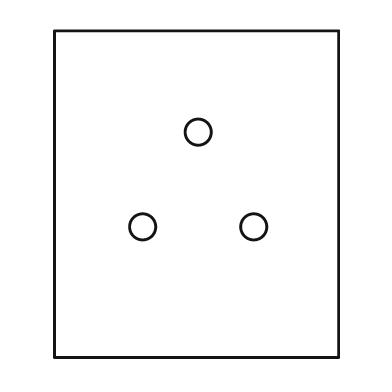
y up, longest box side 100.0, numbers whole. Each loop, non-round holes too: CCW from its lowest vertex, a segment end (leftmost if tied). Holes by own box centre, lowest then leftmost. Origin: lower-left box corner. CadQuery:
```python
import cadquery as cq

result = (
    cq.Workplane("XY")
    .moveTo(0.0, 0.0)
    .lineTo(87.0, 0.0)
    .lineTo(87.0, 100.0)
    .lineTo(0.0, 100.0)
    .close()
    .moveTo(27.0, 40.0)
    .circle(4.0)
    .moveTo(61.0, 40.0)
    .circle(4.0)
    .moveTo(44.0, 69.0)
    .circle(4.0)
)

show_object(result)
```